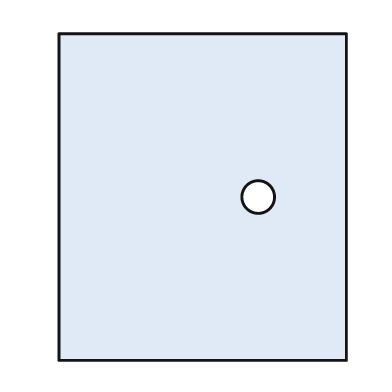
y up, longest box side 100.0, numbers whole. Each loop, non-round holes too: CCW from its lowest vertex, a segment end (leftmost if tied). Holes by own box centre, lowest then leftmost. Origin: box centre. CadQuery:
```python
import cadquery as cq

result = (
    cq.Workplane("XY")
    .moveTo(-44.0, -50.0)
    .lineTo(44.0, -50.0)
    .lineTo(44.0, 50.0)
    .lineTo(-44.0, 50.0)
    .close()
    .moveTo(17.0, 0.0)
    .circle(5.0)
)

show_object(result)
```